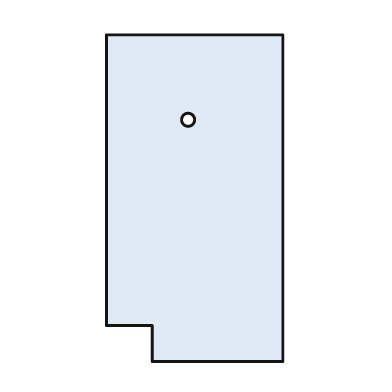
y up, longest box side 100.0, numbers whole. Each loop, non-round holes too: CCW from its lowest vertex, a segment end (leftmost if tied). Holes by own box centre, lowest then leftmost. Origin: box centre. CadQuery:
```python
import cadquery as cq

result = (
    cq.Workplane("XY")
    .moveTo(-13.0, -50.0)
    .lineTo(27.0, -50.0)
    .lineTo(27.0, 50.0)
    .lineTo(-27.0, 50.0)
    .lineTo(-27.0, -39.0)
    .lineTo(-13.0, -39.0)
    .close()
    .moveTo(-2.0, 24.0)
    .circle(2.0)
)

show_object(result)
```